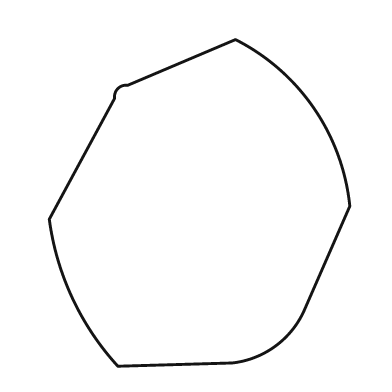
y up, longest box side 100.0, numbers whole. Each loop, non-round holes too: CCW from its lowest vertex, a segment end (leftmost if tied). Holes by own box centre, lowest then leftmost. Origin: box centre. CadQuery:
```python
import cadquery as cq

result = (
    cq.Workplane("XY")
    .moveTo(-25.0, -50.0)
    .lineTo(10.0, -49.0)
    .threePointArc((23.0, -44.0), (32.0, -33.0))
    .lineTo(46.0, -1.0)
    .threePointArc((35.0, 29.0), (11.0, 50.0))
    .lineTo(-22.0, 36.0)
    .threePointArc((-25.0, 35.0), (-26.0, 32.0))
    .lineTo(-46.0, -5.0)
    .threePointArc((-39.0, -29.0), (-25.0, -50.0))
    .close()
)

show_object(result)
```